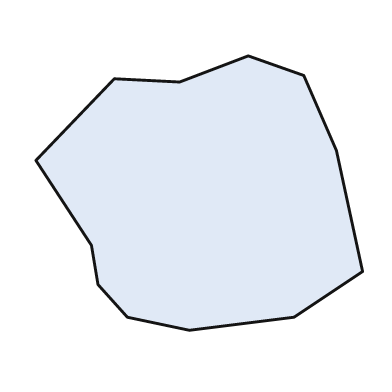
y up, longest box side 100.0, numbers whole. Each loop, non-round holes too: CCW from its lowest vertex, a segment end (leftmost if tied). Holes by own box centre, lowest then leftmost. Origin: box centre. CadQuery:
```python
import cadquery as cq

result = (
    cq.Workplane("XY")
    .moveTo(-3.0, -42.0)
    .lineTo(29.0, -38.0)
    .lineTo(50.0, -24.0)
    .lineTo(42.0, 13.0)
    .lineTo(32.0, 36.0)
    .lineTo(15.0, 42.0)
    .lineTo(-6.0, 34.0)
    .lineTo(-26.0, 35.0)
    .lineTo(-50.0, 10.0)
    .lineTo(-33.0, -16.0)
    .lineTo(-31.0, -28.0)
    .lineTo(-22.0, -38.0)
    .close()
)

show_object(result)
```